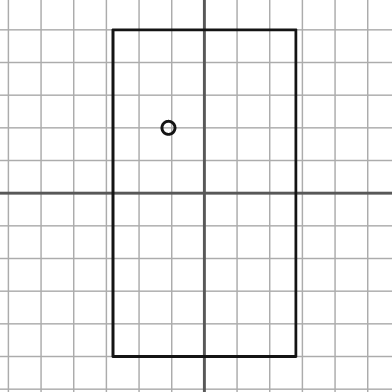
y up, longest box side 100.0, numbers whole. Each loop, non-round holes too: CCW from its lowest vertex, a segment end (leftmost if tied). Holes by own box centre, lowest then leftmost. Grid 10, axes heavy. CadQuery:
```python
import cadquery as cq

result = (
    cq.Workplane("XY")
    .moveTo(-28.0, -50.0)
    .lineTo(28.0, -50.0)
    .lineTo(28.0, 50.0)
    .lineTo(-28.0, 50.0)
    .close()
    .moveTo(-11.0, 20.0)
    .circle(2.0)
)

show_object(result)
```